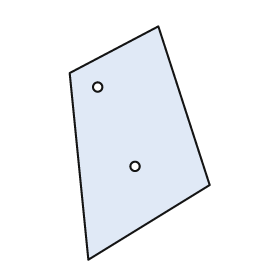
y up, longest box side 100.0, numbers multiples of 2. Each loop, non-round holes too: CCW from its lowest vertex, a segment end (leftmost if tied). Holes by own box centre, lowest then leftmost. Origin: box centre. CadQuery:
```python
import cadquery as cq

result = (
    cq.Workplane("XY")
    .moveTo(-22.0, -50.0)
    .lineTo(30.0, -18.0)
    .lineTo(8.0, 50.0)
    .lineTo(-30.0, 30.0)
    .close()
    .moveTo(-2.0, -10.0)
    .circle(2.0)
    .moveTo(-18.0, 24.0)
    .circle(2.0)
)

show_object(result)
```